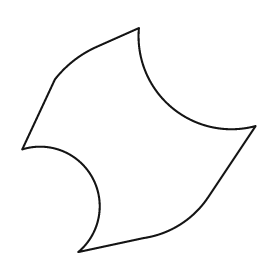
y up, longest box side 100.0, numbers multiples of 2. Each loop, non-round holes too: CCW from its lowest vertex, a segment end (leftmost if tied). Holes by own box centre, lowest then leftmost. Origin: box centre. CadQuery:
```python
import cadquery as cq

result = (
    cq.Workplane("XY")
    .moveTo(-26.0, -48.0)
    .lineTo(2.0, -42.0)
    .threePointArc((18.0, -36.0), (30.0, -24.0))
    .lineTo(50.0, 6.0)
    .threePointArc((14.0, 14.0), (0.0, 48.0))
    .lineTo(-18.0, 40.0)
    .threePointArc((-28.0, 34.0), (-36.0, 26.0))
    .lineTo(-50.0, -4.0)
    .threePointArc((-20.0, -16.0), (-26.0, -48.0))
    .close()
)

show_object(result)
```